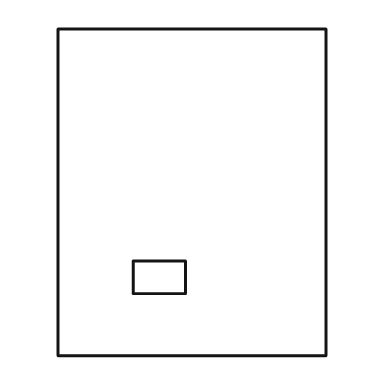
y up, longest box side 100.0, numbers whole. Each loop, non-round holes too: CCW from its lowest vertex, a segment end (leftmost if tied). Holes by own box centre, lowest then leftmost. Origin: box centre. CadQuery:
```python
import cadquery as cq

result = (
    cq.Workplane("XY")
    .moveTo(-41.0, -50.0)
    .lineTo(41.0, -50.0)
    .lineTo(41.0, 50.0)
    .lineTo(-41.0, 50.0)
    .close()
    .moveTo(-18.0, -31.0)
    .lineTo(-2.0, -31.0)
    .lineTo(-2.0, -21.0)
    .lineTo(-18.0, -21.0)
    .close()
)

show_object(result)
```